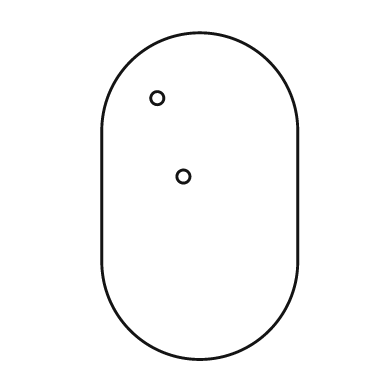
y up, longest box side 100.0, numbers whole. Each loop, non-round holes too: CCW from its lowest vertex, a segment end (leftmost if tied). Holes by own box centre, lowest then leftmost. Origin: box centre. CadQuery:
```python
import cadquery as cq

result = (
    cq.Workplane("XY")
    .moveTo(-30.0, -20.0)
    .threePointArc((0.0, -50.0), (30.0, -20.0))
    .lineTo(30.0, 20.0)
    .threePointArc((0.0, 50.0), (-30.0, 20.0))
    .close()
    .moveTo(-5.0, 6.0)
    .circle(2.0)
    .moveTo(-13.0, 30.0)
    .circle(2.0)
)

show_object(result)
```